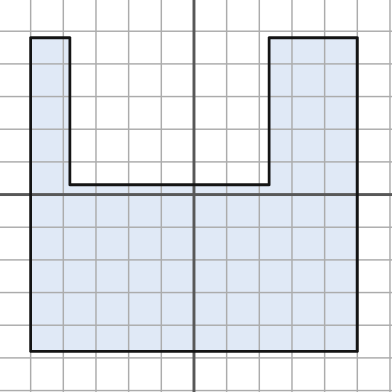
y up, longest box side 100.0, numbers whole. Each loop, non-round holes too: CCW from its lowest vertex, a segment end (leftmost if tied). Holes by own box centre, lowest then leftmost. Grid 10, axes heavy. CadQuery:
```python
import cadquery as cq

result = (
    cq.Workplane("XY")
    .moveTo(-50.0, -48.0)
    .lineTo(50.0, -48.0)
    .lineTo(50.0, 48.0)
    .lineTo(23.0, 48.0)
    .lineTo(23.0, 3.0)
    .lineTo(-38.0, 3.0)
    .lineTo(-38.0, 48.0)
    .lineTo(-50.0, 48.0)
    .close()
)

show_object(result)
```